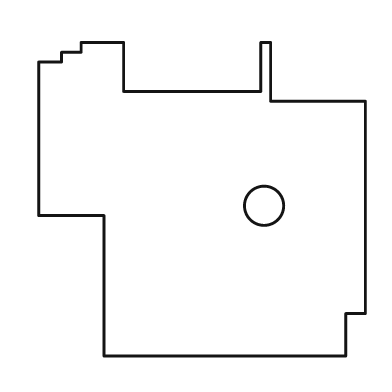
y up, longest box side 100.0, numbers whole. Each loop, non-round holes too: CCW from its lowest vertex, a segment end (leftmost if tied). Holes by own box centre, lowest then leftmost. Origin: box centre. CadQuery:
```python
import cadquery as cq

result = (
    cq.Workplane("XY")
    .moveTo(-30.0, -48.0)
    .lineTo(44.0, -48.0)
    .lineTo(44.0, -35.0)
    .lineTo(50.0, -35.0)
    .lineTo(50.0, 30.0)
    .lineTo(21.0, 30.0)
    .lineTo(21.0, 48.0)
    .lineTo(18.0, 48.0)
    .lineTo(18.0, 33.0)
    .lineTo(-24.0, 33.0)
    .lineTo(-24.0, 48.0)
    .lineTo(-37.0, 48.0)
    .lineTo(-37.0, 45.0)
    .lineTo(-43.0, 45.0)
    .lineTo(-43.0, 42.0)
    .lineTo(-50.0, 42.0)
    .lineTo(-50.0, -5.0)
    .lineTo(-30.0, -5.0)
    .close()
    .moveTo(19.0, -2.0)
    .circle(6.0)
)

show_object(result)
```